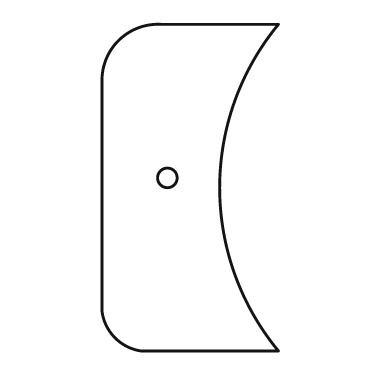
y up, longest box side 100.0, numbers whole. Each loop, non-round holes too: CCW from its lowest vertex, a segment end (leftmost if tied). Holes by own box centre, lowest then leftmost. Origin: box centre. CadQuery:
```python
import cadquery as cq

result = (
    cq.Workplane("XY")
    .moveTo(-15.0, -50.0)
    .lineTo(27.0, -50.0)
    .threePointArc((9.0, 0.0), (27.0, 50.0))
    .lineTo(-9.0, 50.0)
    .threePointArc((-22.0, 45.0), (-27.0, 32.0))
    .lineTo(-27.0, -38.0)
    .threePointArc((-23.0, -46.0), (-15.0, -50.0))
    .close()
    .moveTo(-7.0, 3.0)
    .circle(3.0)
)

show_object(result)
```